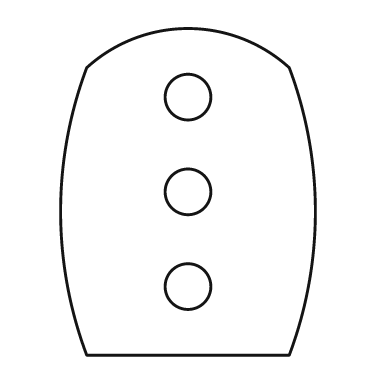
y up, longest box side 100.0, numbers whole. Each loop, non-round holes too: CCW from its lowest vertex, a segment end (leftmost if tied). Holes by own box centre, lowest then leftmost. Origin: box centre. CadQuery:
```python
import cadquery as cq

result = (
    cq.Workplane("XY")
    .moveTo(-31.0, -50.0)
    .lineTo(31.0, -50.0)
    .threePointArc((39.0, -6.0), (31.0, 38.0))
    .threePointArc((0.0, 50.0), (-31.0, 38.0))
    .threePointArc((-39.0, -6.0), (-31.0, -50.0))
    .close()
    .moveTo(0.0, -29.0)
    .circle(7.0)
    .moveTo(0.0, 0.0)
    .circle(7.0)
    .moveTo(0.0, 29.0)
    .circle(7.0)
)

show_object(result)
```